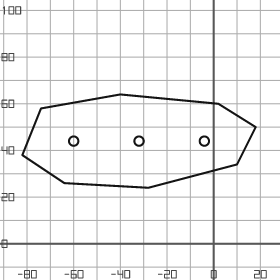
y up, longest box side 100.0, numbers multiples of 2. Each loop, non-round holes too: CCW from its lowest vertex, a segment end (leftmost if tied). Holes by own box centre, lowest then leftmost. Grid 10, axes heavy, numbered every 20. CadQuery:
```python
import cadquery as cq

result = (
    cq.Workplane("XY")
    .moveTo(-28.0, 24.0)
    .lineTo(10.0, 34.0)
    .lineTo(18.0, 50.0)
    .lineTo(2.0, 60.0)
    .lineTo(-40.0, 64.0)
    .lineTo(-74.0, 58.0)
    .lineTo(-82.0, 38.0)
    .lineTo(-64.0, 26.0)
    .close()
    .moveTo(-60.0, 44.0)
    .circle(2.0)
    .moveTo(-32.0, 44.0)
    .circle(2.0)
    .moveTo(-4.0, 44.0)
    .circle(2.0)
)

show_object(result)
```